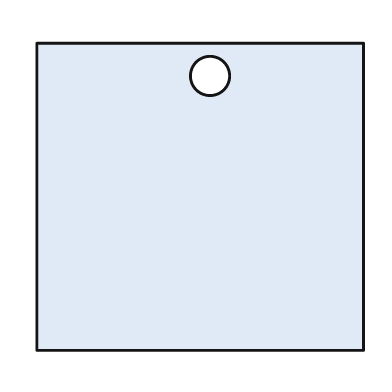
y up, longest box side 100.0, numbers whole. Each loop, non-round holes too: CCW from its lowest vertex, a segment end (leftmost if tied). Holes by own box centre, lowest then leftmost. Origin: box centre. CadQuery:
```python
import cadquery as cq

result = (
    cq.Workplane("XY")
    .moveTo(-50.0, -47.0)
    .lineTo(50.0, -47.0)
    .lineTo(50.0, 47.0)
    .lineTo(-50.0, 47.0)
    .close()
    .moveTo(3.0, 37.0)
    .circle(6.0)
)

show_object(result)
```